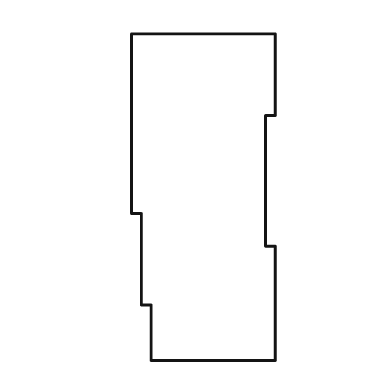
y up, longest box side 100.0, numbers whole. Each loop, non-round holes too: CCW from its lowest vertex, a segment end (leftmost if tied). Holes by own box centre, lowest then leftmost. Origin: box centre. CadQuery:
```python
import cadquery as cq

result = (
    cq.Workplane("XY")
    .moveTo(-16.0, -50.0)
    .lineTo(22.0, -50.0)
    .lineTo(22.0, -15.0)
    .lineTo(19.0, -15.0)
    .lineTo(19.0, 25.0)
    .lineTo(22.0, 25.0)
    .lineTo(22.0, 50.0)
    .lineTo(-22.0, 50.0)
    .lineTo(-22.0, -5.0)
    .lineTo(-19.0, -5.0)
    .lineTo(-19.0, -33.0)
    .lineTo(-16.0, -33.0)
    .close()
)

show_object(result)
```